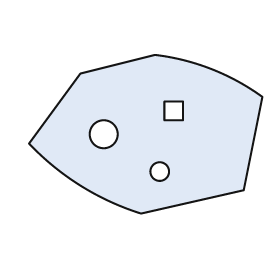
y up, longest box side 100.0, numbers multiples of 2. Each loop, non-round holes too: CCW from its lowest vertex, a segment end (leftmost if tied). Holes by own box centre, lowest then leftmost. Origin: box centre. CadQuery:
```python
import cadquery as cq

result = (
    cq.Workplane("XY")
    .moveTo(-2.0, -34.0)
    .lineTo(42.0, -24.0)
    .lineTo(50.0, 16.0)
    .threePointArc((28.0, 28.0), (4.0, 34.0))
    .lineTo(-28.0, 26.0)
    .lineTo(-50.0, -4.0)
    .threePointArc((-28.0, -22.0), (-2.0, -34.0))
    .close()
    .moveTo(6.0, -16.0)
    .circle(4.0)
    .moveTo(-18.0, 0.0)
    .circle(6.0)
    .moveTo(8.0, 6.0)
    .lineTo(16.0, 6.0)
    .lineTo(16.0, 14.0)
    .lineTo(8.0, 14.0)
    .close()
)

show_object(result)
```